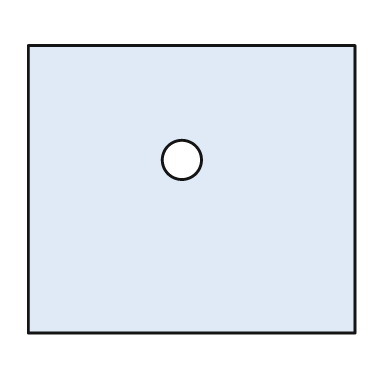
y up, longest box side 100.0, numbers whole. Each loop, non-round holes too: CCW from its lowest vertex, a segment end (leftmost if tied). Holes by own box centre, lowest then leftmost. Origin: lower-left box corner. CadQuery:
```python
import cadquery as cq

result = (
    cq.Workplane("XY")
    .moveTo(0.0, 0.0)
    .lineTo(100.0, 0.0)
    .lineTo(100.0, 88.0)
    .lineTo(0.0, 88.0)
    .close()
    .moveTo(47.0, 53.0)
    .circle(6.0)
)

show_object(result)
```